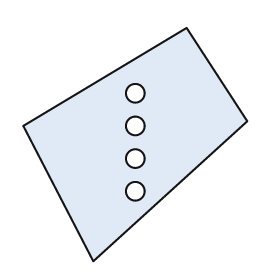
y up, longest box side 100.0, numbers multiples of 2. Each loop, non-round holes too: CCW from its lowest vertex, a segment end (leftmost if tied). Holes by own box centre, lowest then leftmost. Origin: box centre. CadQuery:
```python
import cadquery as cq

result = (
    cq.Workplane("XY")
    .moveTo(-18.0, -50.0)
    .lineTo(48.0, 10.0)
    .lineTo(22.0, 50.0)
    .lineTo(-48.0, 8.0)
    .close()
    .moveTo(0.0, -20.0)
    .circle(4.0)
    .moveTo(0.0, -6.0)
    .circle(4.0)
    .moveTo(0.0, 8.0)
    .circle(4.0)
    .moveTo(0.0, 22.0)
    .circle(4.0)
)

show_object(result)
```